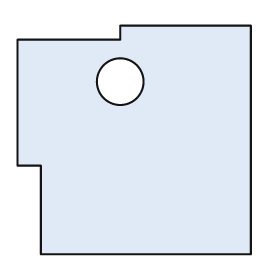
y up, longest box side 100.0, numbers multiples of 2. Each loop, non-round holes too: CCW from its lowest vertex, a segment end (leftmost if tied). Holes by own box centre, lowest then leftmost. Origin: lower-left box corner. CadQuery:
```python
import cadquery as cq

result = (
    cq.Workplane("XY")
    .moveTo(10.0, 0.0)
    .lineTo(100.0, 0.0)
    .lineTo(100.0, 98.0)
    .lineTo(44.0, 98.0)
    .lineTo(44.0, 92.0)
    .lineTo(0.0, 92.0)
    .lineTo(0.0, 38.0)
    .lineTo(10.0, 38.0)
    .close()
    .moveTo(44.0, 74.0)
    .circle(10.0)
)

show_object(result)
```